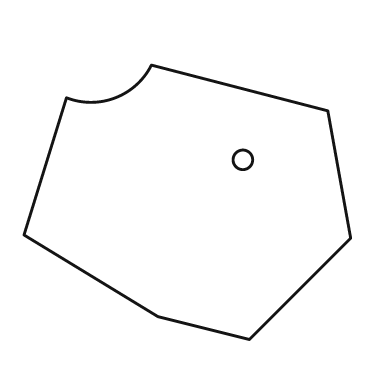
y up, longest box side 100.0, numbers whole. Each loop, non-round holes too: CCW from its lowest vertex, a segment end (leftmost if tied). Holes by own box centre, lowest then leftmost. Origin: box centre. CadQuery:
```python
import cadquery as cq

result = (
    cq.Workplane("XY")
    .moveTo(19.0, -42.0)
    .lineTo(50.0, -11.0)
    .lineTo(43.0, 28.0)
    .lineTo(-11.0, 42.0)
    .threePointArc((-22.0, 32.0), (-37.0, 32.0))
    .lineTo(-50.0, -10.0)
    .lineTo(-9.0, -35.0)
    .close()
    .moveTo(17.0, 13.0)
    .circle(3.0)
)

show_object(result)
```